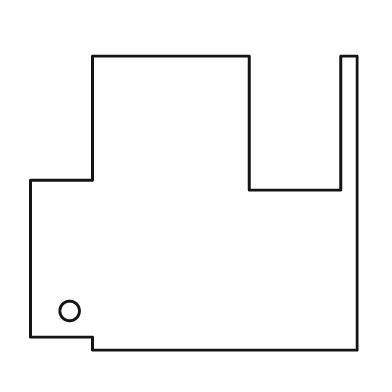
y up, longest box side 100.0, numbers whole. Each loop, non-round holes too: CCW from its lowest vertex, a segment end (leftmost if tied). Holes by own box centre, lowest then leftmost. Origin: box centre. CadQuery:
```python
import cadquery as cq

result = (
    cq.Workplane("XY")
    .moveTo(-31.0, -45.0)
    .lineTo(50.0, -45.0)
    .lineTo(50.0, 45.0)
    .lineTo(45.0, 45.0)
    .lineTo(45.0, 4.0)
    .lineTo(17.0, 4.0)
    .lineTo(17.0, 45.0)
    .lineTo(-31.0, 45.0)
    .lineTo(-31.0, 7.0)
    .lineTo(-50.0, 7.0)
    .lineTo(-50.0, -41.0)
    .lineTo(-31.0, -41.0)
    .close()
    .moveTo(-38.0, -33.0)
    .circle(3.0)
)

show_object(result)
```